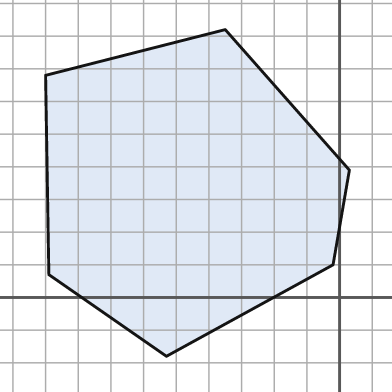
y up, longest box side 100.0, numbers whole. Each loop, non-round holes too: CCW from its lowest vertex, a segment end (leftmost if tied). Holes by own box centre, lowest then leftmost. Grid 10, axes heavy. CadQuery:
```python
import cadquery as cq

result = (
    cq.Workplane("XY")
    .moveTo(-53.0, -18.0)
    .lineTo(-2.0, 10.0)
    .lineTo(3.0, 39.0)
    .lineTo(-35.0, 82.0)
    .lineTo(-90.0, 68.0)
    .lineTo(-89.0, 7.0)
    .close()
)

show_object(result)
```